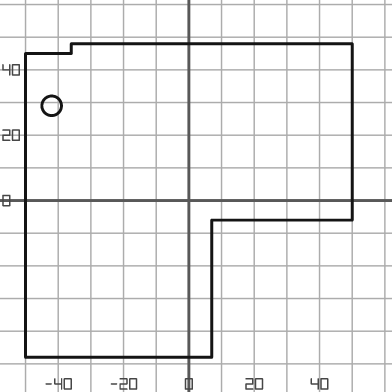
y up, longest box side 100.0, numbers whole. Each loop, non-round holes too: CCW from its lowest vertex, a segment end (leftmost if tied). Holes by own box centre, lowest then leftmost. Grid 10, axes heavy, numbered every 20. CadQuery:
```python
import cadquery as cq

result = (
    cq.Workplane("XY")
    .moveTo(-50.0, -48.0)
    .lineTo(7.0, -48.0)
    .lineTo(7.0, -6.0)
    .lineTo(50.0, -6.0)
    .lineTo(50.0, 48.0)
    .lineTo(-36.0, 48.0)
    .lineTo(-36.0, 45.0)
    .lineTo(-50.0, 45.0)
    .close()
    .moveTo(-42.0, 29.0)
    .circle(3.0)
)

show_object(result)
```